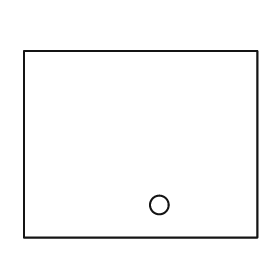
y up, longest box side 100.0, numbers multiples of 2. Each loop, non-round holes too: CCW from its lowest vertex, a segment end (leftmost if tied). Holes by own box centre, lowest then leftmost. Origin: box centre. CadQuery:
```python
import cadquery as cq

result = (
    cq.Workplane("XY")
    .moveTo(-50.0, -40.0)
    .lineTo(50.0, -40.0)
    .lineTo(50.0, 40.0)
    .lineTo(-50.0, 40.0)
    .close()
    .moveTo(8.0, -26.0)
    .circle(4.0)
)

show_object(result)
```